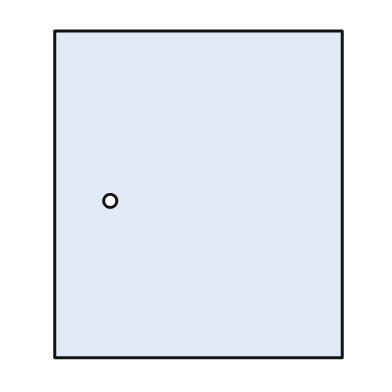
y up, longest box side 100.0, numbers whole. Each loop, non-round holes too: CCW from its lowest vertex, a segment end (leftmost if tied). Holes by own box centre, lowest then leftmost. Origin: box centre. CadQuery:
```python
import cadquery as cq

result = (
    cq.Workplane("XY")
    .moveTo(-44.0, -50.0)
    .lineTo(44.0, -50.0)
    .lineTo(44.0, 50.0)
    .lineTo(-44.0, 50.0)
    .close()
    .moveTo(-27.0, -2.0)
    .circle(2.0)
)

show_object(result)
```